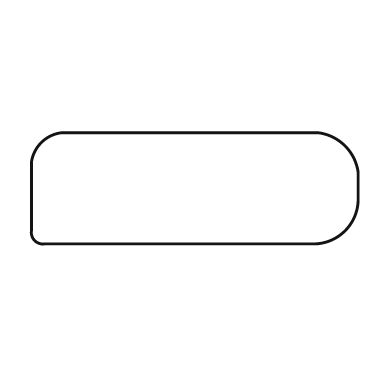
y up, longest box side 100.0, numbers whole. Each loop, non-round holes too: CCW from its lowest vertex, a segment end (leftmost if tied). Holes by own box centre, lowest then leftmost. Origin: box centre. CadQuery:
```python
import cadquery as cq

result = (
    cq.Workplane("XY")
    .moveTo(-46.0, -17.0)
    .lineTo(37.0, -17.0)
    .threePointArc((46.0, -13.0), (50.0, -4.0))
    .lineTo(50.0, 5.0)
    .threePointArc((46.0, 13.0), (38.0, 17.0))
    .lineTo(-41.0, 17.0)
    .threePointArc((-47.0, 14.0), (-50.0, 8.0))
    .lineTo(-50.0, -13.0)
    .threePointArc((-49.0, -16.0), (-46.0, -17.0))
    .close()
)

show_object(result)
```